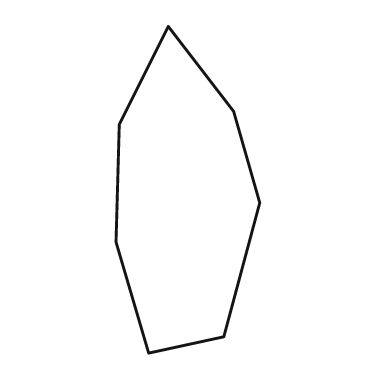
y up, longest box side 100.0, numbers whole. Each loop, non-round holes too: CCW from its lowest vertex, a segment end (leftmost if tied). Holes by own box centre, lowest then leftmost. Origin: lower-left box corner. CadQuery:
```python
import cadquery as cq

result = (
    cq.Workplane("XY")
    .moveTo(10.0, 0.0)
    .lineTo(33.0, 5.0)
    .lineTo(44.0, 46.0)
    .lineTo(36.0, 74.0)
    .lineTo(16.0, 100.0)
    .lineTo(1.0, 70.0)
    .lineTo(0.0, 34.0)
    .close()
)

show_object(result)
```